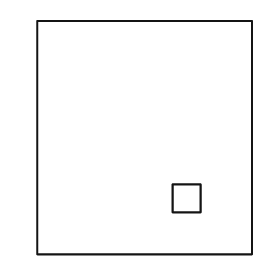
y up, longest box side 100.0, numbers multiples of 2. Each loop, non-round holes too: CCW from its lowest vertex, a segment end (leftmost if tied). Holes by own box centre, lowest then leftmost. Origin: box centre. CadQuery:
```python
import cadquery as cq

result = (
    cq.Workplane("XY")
    .moveTo(-46.0, -50.0)
    .lineTo(46.0, -50.0)
    .lineTo(46.0, 50.0)
    .lineTo(-46.0, 50.0)
    .close()
    .moveTo(12.0, -32.0)
    .lineTo(24.0, -32.0)
    .lineTo(24.0, -20.0)
    .lineTo(12.0, -20.0)
    .close()
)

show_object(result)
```